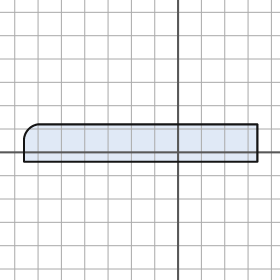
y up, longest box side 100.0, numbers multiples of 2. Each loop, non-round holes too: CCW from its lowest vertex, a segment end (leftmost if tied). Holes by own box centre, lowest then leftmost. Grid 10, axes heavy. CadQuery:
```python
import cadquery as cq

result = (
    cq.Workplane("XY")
    .moveTo(-66.0, -4.0)
    .lineTo(34.0, -4.0)
    .lineTo(34.0, 12.0)
    .lineTo(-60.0, 12.0)
    .threePointArc((-64.0, 10.0), (-66.0, 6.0))
    .close()
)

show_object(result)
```